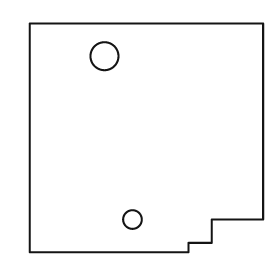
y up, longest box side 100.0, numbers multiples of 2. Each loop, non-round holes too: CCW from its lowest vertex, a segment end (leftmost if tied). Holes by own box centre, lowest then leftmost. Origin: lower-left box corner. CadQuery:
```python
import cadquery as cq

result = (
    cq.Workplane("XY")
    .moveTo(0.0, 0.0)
    .lineTo(68.0, 0.0)
    .lineTo(68.0, 4.0)
    .lineTo(78.0, 4.0)
    .lineTo(78.0, 14.0)
    .lineTo(100.0, 14.0)
    .lineTo(100.0, 98.0)
    .lineTo(0.0, 98.0)
    .close()
    .moveTo(44.0, 14.0)
    .circle(4.0)
    .moveTo(32.0, 84.0)
    .circle(6.0)
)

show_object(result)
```